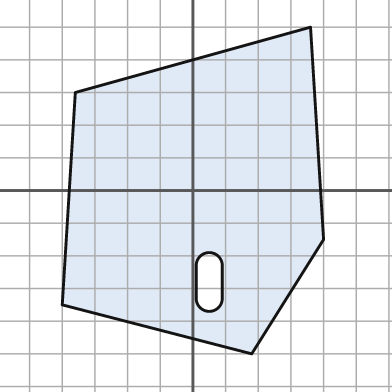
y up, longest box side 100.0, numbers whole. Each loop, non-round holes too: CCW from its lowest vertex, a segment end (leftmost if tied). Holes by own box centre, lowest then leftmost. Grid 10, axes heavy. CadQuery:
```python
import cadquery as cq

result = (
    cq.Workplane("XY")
    .moveTo(18.0, -50.0)
    .lineTo(40.0, -15.0)
    .lineTo(36.0, 50.0)
    .lineTo(-36.0, 30.0)
    .lineTo(-40.0, -35.0)
    .close()
    .moveTo(1.0, -33.0)
    .threePointArc((5.0, -37.0), (9.0, -33.0))
    .lineTo(9.0, -23.0)
    .threePointArc((5.0, -19.0), (1.0, -23.0))
    .close()
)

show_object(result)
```